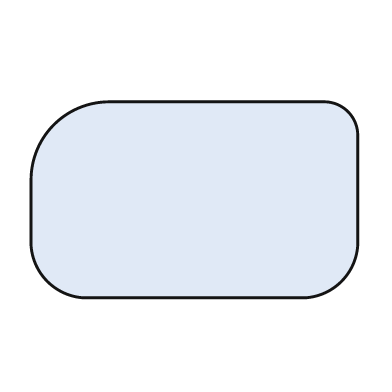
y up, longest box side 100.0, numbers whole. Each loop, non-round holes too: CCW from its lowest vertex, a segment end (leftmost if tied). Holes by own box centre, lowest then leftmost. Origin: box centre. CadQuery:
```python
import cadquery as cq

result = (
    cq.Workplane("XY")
    .moveTo(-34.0, -30.0)
    .lineTo(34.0, -30.0)
    .threePointArc((45.0, -25.0), (50.0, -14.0))
    .lineTo(50.0, 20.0)
    .threePointArc((47.0, 27.0), (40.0, 30.0))
    .lineTo(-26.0, 30.0)
    .threePointArc((-43.0, 23.0), (-50.0, 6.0))
    .lineTo(-50.0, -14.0)
    .threePointArc((-45.0, -25.0), (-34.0, -30.0))
    .close()
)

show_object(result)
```